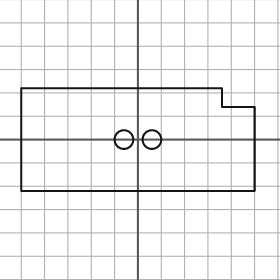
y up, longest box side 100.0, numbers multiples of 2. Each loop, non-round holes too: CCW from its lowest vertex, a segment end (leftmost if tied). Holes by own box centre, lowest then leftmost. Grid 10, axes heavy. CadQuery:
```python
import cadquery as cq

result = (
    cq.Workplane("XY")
    .moveTo(-50.0, -22.0)
    .lineTo(50.0, -22.0)
    .lineTo(50.0, 14.0)
    .lineTo(36.0, 14.0)
    .lineTo(36.0, 22.0)
    .lineTo(-50.0, 22.0)
    .close()
    .moveTo(-6.0, 0.0)
    .circle(4.0)
    .moveTo(6.0, 0.0)
    .circle(4.0)
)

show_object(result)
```